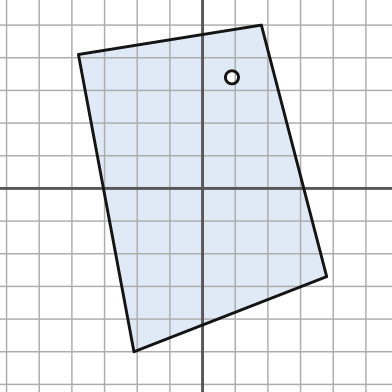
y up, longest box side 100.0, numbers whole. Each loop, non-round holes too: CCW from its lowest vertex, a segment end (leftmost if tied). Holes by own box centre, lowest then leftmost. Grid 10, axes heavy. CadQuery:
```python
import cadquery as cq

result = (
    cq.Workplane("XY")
    .moveTo(-21.0, -50.0)
    .lineTo(38.0, -27.0)
    .lineTo(18.0, 50.0)
    .lineTo(-38.0, 41.0)
    .close()
    .moveTo(9.0, 34.0)
    .circle(2.0)
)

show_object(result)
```